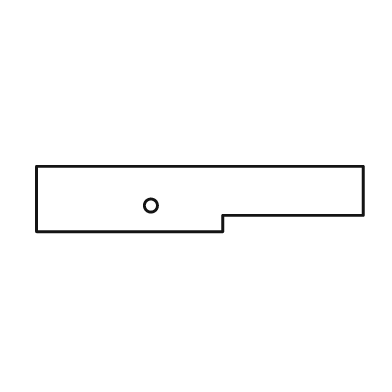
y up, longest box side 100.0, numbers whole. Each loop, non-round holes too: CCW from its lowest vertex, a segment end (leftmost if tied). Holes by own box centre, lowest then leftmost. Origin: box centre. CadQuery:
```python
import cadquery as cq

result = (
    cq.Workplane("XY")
    .moveTo(-50.0, -10.0)
    .lineTo(7.0, -10.0)
    .lineTo(7.0, -5.0)
    .lineTo(50.0, -5.0)
    .lineTo(50.0, 10.0)
    .lineTo(-50.0, 10.0)
    .close()
    .moveTo(-15.0, -2.0)
    .circle(2.0)
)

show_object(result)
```